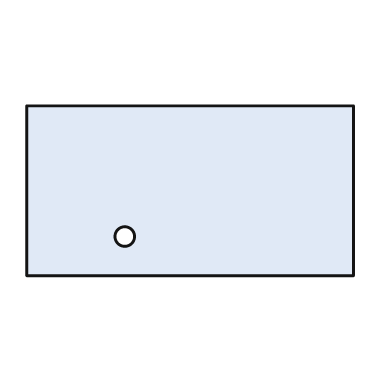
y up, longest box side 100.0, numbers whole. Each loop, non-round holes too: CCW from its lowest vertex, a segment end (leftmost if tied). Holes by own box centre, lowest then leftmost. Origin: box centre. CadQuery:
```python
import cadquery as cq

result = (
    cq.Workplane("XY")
    .moveTo(-50.0, -26.0)
    .lineTo(50.0, -26.0)
    .lineTo(50.0, 26.0)
    .lineTo(-50.0, 26.0)
    .close()
    .moveTo(-20.0, -14.0)
    .circle(3.0)
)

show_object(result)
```